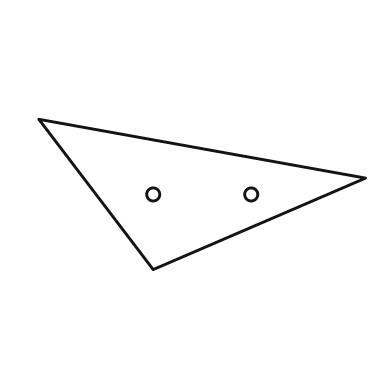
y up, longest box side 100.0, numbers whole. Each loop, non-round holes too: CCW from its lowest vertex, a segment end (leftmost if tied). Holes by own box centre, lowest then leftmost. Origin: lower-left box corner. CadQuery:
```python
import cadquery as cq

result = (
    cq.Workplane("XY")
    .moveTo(35.0, 0.0)
    .lineTo(100.0, 28.0)
    .lineTo(0.0, 46.0)
    .close()
    .moveTo(35.0, 23.0)
    .circle(2.0)
    .moveTo(65.0, 23.0)
    .circle(2.0)
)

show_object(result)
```